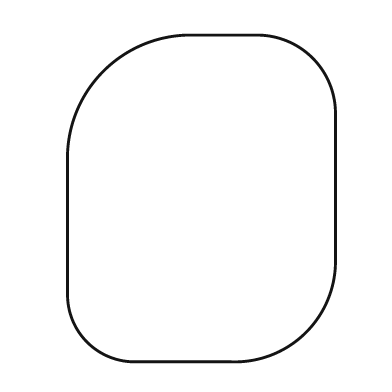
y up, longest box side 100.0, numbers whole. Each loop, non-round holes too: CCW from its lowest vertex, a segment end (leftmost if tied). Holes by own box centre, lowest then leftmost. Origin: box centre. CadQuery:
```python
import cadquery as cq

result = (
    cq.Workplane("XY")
    .moveTo(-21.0, -50.0)
    .lineTo(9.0, -50.0)
    .threePointArc((32.0, -41.0), (41.0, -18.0))
    .lineTo(41.0, 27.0)
    .threePointArc((34.0, 43.0), (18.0, 50.0))
    .lineTo(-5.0, 50.0)
    .threePointArc((-30.0, 39.0), (-41.0, 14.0))
    .lineTo(-41.0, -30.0)
    .threePointArc((-35.0, -44.0), (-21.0, -50.0))
    .close()
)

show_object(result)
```